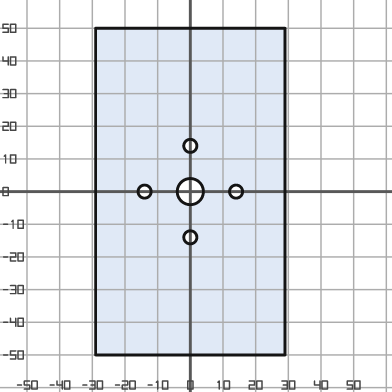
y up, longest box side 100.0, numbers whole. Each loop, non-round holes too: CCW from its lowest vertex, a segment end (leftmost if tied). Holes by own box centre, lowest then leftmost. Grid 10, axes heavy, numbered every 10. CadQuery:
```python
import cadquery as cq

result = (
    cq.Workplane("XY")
    .moveTo(-29.0, -50.0)
    .lineTo(29.0, -50.0)
    .lineTo(29.0, 50.0)
    .lineTo(-29.0, 50.0)
    .close()
    .moveTo(0.0, -14.0)
    .circle(2.0)
    .moveTo(-14.0, 0.0)
    .circle(2.0)
    .moveTo(0.0, 0.0)
    .circle(4.0)
    .moveTo(14.0, 0.0)
    .circle(2.0)
    .moveTo(0.0, 14.0)
    .circle(2.0)
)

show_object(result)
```